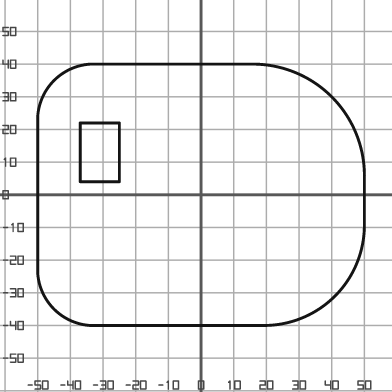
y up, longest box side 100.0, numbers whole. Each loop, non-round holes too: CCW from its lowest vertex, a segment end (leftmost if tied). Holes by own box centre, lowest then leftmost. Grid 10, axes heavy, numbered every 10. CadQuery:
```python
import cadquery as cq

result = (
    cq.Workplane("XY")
    .moveTo(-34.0, -40.0)
    .lineTo(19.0, -40.0)
    .threePointArc((41.0, -31.0), (50.0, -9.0))
    .lineTo(50.0, 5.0)
    .threePointArc((40.0, 30.0), (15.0, 40.0))
    .lineTo(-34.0, 40.0)
    .threePointArc((-45.0, 35.0), (-50.0, 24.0))
    .lineTo(-50.0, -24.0)
    .threePointArc((-45.0, -35.0), (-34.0, -40.0))
    .close()
    .moveTo(-37.0, 4.0)
    .lineTo(-25.0, 4.0)
    .lineTo(-25.0, 22.0)
    .lineTo(-37.0, 22.0)
    .close()
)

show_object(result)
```